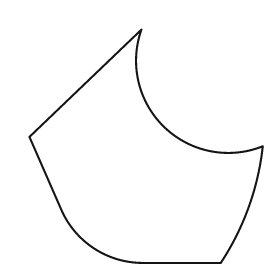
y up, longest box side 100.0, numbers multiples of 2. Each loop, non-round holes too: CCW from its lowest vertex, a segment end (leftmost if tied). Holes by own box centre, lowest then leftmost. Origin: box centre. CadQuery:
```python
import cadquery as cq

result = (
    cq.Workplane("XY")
    .moveTo(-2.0, -50.0)
    .lineTo(32.0, -50.0)
    .threePointArc((44.0, -26.0), (50.0, 0.0))
    .threePointArc((8.0, 8.0), (-2.0, 50.0))
    .lineTo(-50.0, 4.0)
    .lineTo(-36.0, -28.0)
    .threePointArc((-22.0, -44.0), (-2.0, -50.0))
    .close()
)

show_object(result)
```